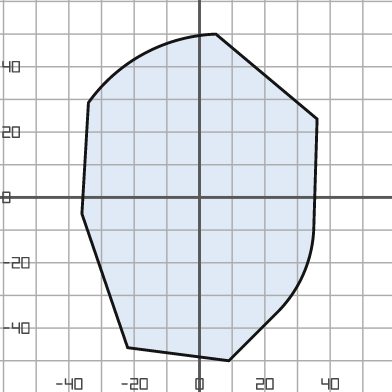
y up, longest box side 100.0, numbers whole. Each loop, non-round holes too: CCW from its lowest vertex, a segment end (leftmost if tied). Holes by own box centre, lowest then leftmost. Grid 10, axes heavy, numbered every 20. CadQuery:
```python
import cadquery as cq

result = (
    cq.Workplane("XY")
    .moveTo(9.0, -50.0)
    .lineTo(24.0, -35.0)
    .threePointArc((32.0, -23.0), (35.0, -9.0))
    .lineTo(36.0, 24.0)
    .lineTo(5.0, 50.0)
    .threePointArc((-17.0, 44.0), (-34.0, 29.0))
    .lineTo(-36.0, -5.0)
    .lineTo(-22.0, -46.0)
    .close()
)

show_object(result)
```